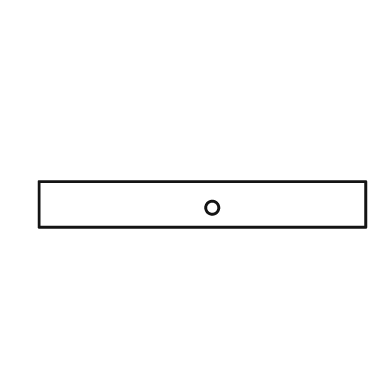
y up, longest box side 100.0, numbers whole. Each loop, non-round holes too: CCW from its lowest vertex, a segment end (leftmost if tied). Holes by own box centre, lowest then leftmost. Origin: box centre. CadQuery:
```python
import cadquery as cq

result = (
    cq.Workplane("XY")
    .moveTo(-50.0, -7.0)
    .lineTo(50.0, -7.0)
    .lineTo(50.0, 7.0)
    .lineTo(-50.0, 7.0)
    .close()
    .moveTo(3.0, -1.0)
    .circle(2.0)
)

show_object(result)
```